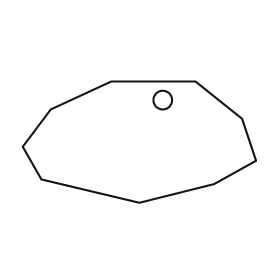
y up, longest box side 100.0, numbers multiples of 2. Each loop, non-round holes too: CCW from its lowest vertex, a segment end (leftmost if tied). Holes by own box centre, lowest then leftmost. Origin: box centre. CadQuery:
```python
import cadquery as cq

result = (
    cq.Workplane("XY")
    .moveTo(0.0, -26.0)
    .lineTo(32.0, -18.0)
    .lineTo(50.0, -8.0)
    .lineTo(44.0, 10.0)
    .lineTo(24.0, 26.0)
    .lineTo(-12.0, 26.0)
    .lineTo(-38.0, 14.0)
    .lineTo(-50.0, -2.0)
    .lineTo(-42.0, -16.0)
    .close()
    .moveTo(10.0, 18.0)
    .circle(4.0)
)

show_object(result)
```